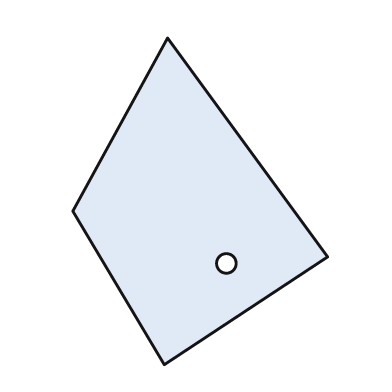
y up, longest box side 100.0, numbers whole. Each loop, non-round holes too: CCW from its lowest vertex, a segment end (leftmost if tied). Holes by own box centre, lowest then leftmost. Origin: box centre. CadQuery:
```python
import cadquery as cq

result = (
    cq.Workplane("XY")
    .moveTo(-11.0, -50.0)
    .lineTo(39.0, -17.0)
    .lineTo(-10.0, 50.0)
    .lineTo(-39.0, -3.0)
    .close()
    .moveTo(8.0, -19.0)
    .circle(3.0)
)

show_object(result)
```